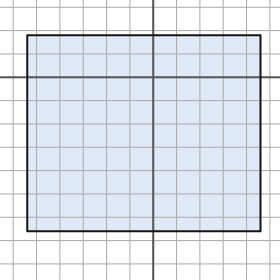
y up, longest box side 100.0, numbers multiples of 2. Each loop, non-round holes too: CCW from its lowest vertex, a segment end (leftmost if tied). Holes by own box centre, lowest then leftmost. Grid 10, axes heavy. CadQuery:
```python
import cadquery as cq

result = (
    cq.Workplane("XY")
    .moveTo(-54.0, -66.0)
    .lineTo(46.0, -66.0)
    .lineTo(46.0, 18.0)
    .lineTo(-54.0, 18.0)
    .close()
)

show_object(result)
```